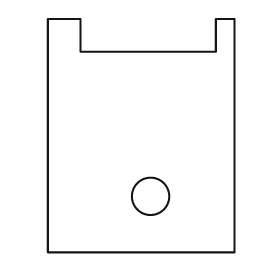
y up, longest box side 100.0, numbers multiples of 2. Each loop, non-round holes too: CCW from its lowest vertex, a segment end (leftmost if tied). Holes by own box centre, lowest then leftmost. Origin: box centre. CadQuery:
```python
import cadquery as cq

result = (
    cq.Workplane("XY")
    .moveTo(-40.0, -50.0)
    .lineTo(40.0, -50.0)
    .lineTo(40.0, 50.0)
    .lineTo(32.0, 50.0)
    .lineTo(32.0, 36.0)
    .lineTo(-26.0, 36.0)
    .lineTo(-26.0, 50.0)
    .lineTo(-40.0, 50.0)
    .close()
    .moveTo(4.0, -26.0)
    .circle(8.0)
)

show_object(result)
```